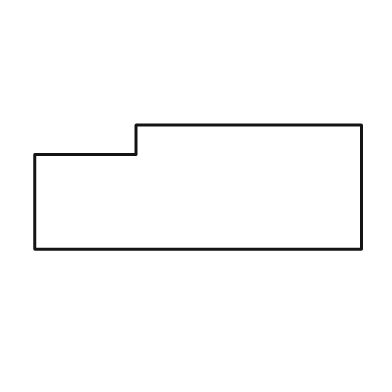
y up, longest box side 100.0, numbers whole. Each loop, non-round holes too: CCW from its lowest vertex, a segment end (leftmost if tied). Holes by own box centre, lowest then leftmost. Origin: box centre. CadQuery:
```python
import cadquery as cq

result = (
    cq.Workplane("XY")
    .moveTo(-50.0, -19.0)
    .lineTo(50.0, -19.0)
    .lineTo(50.0, 19.0)
    .lineTo(-19.0, 19.0)
    .lineTo(-19.0, 10.0)
    .lineTo(-50.0, 10.0)
    .close()
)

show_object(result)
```